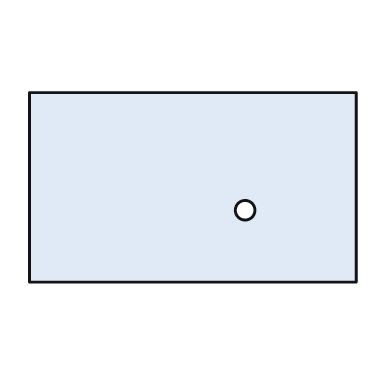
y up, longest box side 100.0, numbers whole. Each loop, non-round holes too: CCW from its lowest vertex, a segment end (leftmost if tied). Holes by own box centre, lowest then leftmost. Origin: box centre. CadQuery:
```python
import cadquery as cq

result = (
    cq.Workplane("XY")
    .moveTo(-50.0, -29.0)
    .lineTo(50.0, -29.0)
    .lineTo(50.0, 29.0)
    .lineTo(-50.0, 29.0)
    .close()
    .moveTo(16.0, -7.0)
    .circle(3.0)
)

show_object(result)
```